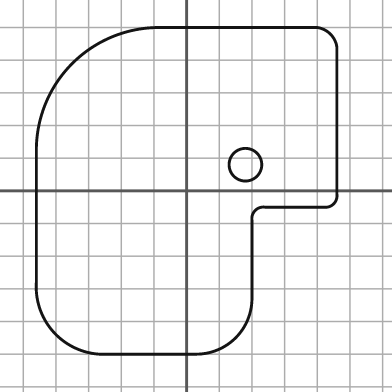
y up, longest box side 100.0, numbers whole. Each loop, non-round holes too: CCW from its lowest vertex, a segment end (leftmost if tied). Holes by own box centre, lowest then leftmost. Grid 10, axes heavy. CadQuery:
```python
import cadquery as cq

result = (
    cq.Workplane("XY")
    .moveTo(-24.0, -50.0)
    .lineTo(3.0, -50.0)
    .threePointArc((15.0, -45.0), (20.0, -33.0))
    .lineTo(20.0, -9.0)
    .threePointArc((21.0, -6.0), (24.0, -5.0))
    .lineTo(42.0, -5.0)
    .threePointArc((45.0, -4.0), (46.0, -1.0))
    .lineTo(46.0, 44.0)
    .threePointArc((44.0, 48.0), (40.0, 50.0))
    .lineTo(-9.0, 50.0)
    .threePointArc((-35.0, 39.0), (-46.0, 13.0))
    .lineTo(-46.0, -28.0)
    .threePointArc((-40.0, -44.0), (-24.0, -50.0))
    .close()
    .moveTo(18.0, 8.0)
    .circle(5.0)
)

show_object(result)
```